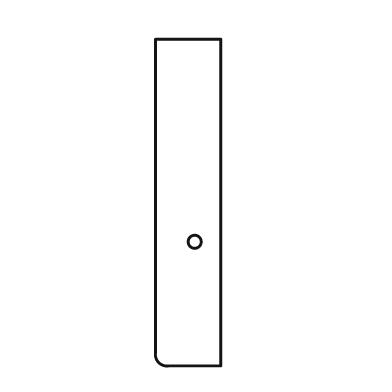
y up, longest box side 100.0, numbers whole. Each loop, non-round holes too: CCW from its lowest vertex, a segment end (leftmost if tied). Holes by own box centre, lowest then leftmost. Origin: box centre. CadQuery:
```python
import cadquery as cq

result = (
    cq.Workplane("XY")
    .moveTo(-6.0, -50.0)
    .lineTo(10.0, -50.0)
    .lineTo(10.0, 50.0)
    .lineTo(-10.0, 50.0)
    .lineTo(-10.0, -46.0)
    .threePointArc((-9.0, -49.0), (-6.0, -50.0))
    .close()
    .moveTo(2.0, -12.0)
    .circle(2.0)
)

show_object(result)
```